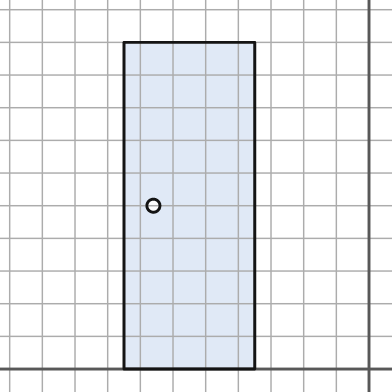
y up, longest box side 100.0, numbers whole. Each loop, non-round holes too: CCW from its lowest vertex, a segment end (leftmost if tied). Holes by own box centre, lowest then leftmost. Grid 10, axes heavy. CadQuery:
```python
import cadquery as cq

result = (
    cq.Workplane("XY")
    .moveTo(-75.0, 0.0)
    .lineTo(-35.0, 0.0)
    .lineTo(-35.0, 100.0)
    .lineTo(-75.0, 100.0)
    .close()
    .moveTo(-66.0, 50.0)
    .circle(2.0)
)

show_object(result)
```